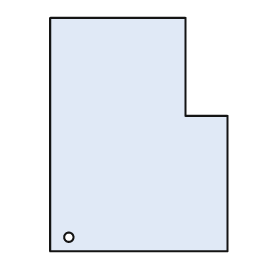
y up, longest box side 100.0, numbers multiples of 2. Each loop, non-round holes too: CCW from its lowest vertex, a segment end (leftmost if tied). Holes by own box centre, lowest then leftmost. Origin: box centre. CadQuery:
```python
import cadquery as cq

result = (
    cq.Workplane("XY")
    .moveTo(-38.0, -50.0)
    .lineTo(38.0, -50.0)
    .lineTo(38.0, 8.0)
    .lineTo(20.0, 8.0)
    .lineTo(20.0, 50.0)
    .lineTo(-38.0, 50.0)
    .close()
    .moveTo(-30.0, -44.0)
    .circle(2.0)
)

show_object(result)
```